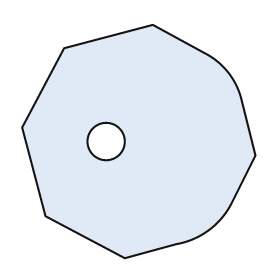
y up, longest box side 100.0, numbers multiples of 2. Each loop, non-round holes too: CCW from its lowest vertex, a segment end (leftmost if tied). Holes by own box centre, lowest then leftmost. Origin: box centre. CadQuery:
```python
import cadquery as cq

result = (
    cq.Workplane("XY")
    .moveTo(-6.0, -50.0)
    .lineTo(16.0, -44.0)
    .threePointArc((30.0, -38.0), (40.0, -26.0))
    .lineTo(50.0, -6.0)
    .lineTo(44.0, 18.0)
    .threePointArc((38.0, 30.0), (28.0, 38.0))
    .lineTo(6.0, 50.0)
    .lineTo(-32.0, 40.0)
    .lineTo(-50.0, 6.0)
    .lineTo(-40.0, -32.0)
    .close()
    .moveTo(-14.0, 0.0)
    .circle(8.0)
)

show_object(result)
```